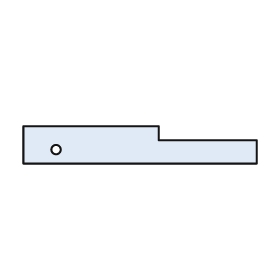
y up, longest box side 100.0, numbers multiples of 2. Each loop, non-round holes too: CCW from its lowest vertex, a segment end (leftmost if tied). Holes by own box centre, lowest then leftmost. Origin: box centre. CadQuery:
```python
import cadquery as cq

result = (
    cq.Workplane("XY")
    .moveTo(-50.0, -8.0)
    .lineTo(50.0, -8.0)
    .lineTo(50.0, 2.0)
    .lineTo(8.0, 2.0)
    .lineTo(8.0, 8.0)
    .lineTo(-50.0, 8.0)
    .close()
    .moveTo(-36.0, -2.0)
    .circle(2.0)
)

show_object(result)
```